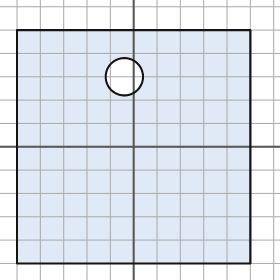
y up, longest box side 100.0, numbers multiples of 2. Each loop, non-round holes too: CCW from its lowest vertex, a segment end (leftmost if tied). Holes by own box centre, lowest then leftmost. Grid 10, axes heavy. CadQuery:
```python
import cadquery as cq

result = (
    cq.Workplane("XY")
    .moveTo(-50.0, -50.0)
    .lineTo(50.0, -50.0)
    .lineTo(50.0, 50.0)
    .lineTo(-50.0, 50.0)
    .close()
    .moveTo(-4.0, 30.0)
    .circle(8.0)
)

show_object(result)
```